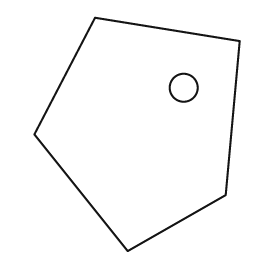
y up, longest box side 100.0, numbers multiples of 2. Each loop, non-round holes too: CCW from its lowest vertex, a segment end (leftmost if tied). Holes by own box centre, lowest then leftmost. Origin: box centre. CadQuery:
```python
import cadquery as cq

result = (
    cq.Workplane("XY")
    .moveTo(-4.0, -50.0)
    .lineTo(38.0, -26.0)
    .lineTo(44.0, 40.0)
    .lineTo(-18.0, 50.0)
    .lineTo(-44.0, 0.0)
    .close()
    .moveTo(20.0, 20.0)
    .circle(6.0)
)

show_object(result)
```